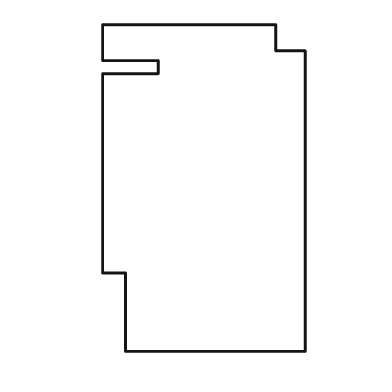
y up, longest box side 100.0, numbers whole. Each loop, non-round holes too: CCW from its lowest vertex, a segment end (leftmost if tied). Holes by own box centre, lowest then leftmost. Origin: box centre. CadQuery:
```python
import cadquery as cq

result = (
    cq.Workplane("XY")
    .moveTo(-24.0, -50.0)
    .lineTo(31.0, -50.0)
    .lineTo(31.0, 42.0)
    .lineTo(22.0, 42.0)
    .lineTo(22.0, 50.0)
    .lineTo(-31.0, 50.0)
    .lineTo(-31.0, 39.0)
    .lineTo(-14.0, 39.0)
    .lineTo(-14.0, 35.0)
    .lineTo(-31.0, 35.0)
    .lineTo(-31.0, -26.0)
    .lineTo(-24.0, -26.0)
    .close()
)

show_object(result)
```